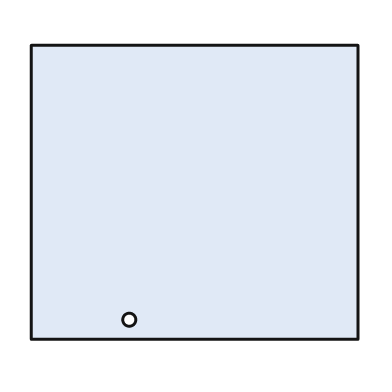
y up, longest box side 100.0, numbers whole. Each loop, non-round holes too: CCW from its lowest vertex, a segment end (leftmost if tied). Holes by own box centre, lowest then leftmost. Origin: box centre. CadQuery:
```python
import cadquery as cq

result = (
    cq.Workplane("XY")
    .moveTo(-50.0, -45.0)
    .lineTo(50.0, -45.0)
    .lineTo(50.0, 45.0)
    .lineTo(-50.0, 45.0)
    .close()
    .moveTo(-20.0, -39.0)
    .circle(2.0)
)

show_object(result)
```